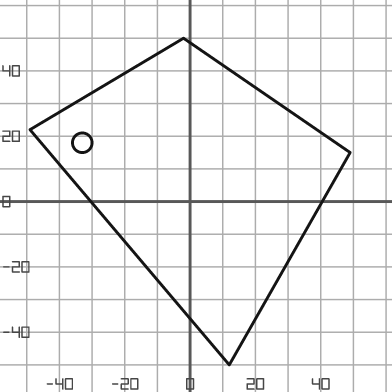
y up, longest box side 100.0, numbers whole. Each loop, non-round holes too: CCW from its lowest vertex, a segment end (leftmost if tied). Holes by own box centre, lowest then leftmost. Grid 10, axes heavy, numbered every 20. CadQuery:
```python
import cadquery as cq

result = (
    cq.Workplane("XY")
    .moveTo(12.0, -50.0)
    .lineTo(49.0, 15.0)
    .lineTo(-2.0, 50.0)
    .lineTo(-49.0, 22.0)
    .close()
    .moveTo(-33.0, 18.0)
    .circle(3.0)
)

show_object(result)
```